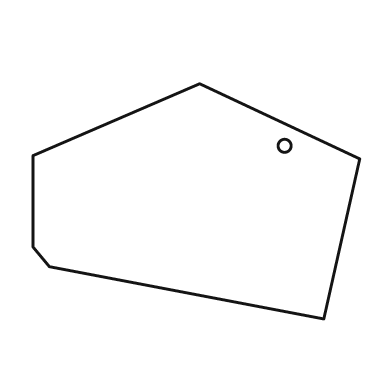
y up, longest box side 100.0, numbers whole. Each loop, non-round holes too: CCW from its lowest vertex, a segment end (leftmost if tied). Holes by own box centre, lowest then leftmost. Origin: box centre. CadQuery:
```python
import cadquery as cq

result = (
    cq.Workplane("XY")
    .moveTo(39.0, -36.0)
    .lineTo(50.0, 13.0)
    .lineTo(1.0, 36.0)
    .lineTo(-50.0, 14.0)
    .lineTo(-50.0, -14.0)
    .lineTo(-45.0, -20.0)
    .close()
    .moveTo(27.0, 17.0)
    .circle(2.0)
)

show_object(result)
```